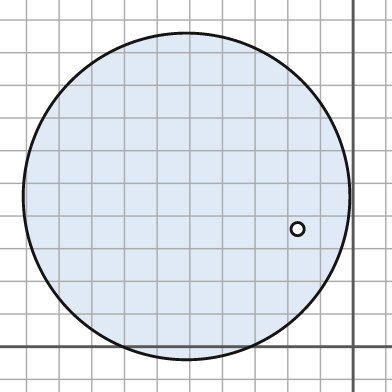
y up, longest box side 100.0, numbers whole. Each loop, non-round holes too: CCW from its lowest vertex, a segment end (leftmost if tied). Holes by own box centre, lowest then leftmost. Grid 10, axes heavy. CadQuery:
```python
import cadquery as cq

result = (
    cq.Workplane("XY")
    .moveTo(-51.0, 46.0)
    .circle(50.0)
    .moveTo(-17.0, 36.0)
    .circle(2.0)
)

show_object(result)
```